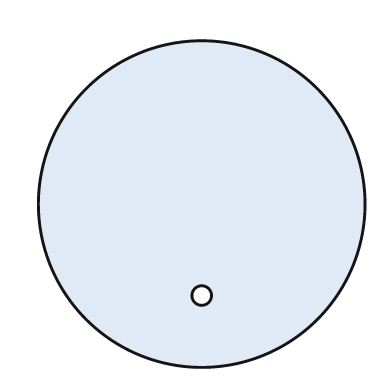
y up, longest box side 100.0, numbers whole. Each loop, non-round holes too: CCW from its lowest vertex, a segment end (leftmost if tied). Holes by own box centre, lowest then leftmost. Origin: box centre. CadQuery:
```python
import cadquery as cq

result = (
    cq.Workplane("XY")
    .moveTo(0.0, 0.0)
    .circle(50.0)
    .moveTo(0.0, -28.0)
    .circle(3.0)
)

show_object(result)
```